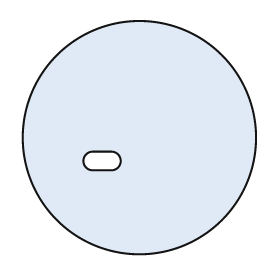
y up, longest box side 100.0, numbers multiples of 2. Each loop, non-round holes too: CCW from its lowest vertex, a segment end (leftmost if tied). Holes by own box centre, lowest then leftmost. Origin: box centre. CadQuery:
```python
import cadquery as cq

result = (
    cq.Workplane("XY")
    .moveTo(0.0, 0.0)
    .circle(50.0)
    .moveTo(-20.0, -14.0)
    .lineTo(-12.0, -14.0)
    .threePointArc((-8.0, -10.0), (-12.0, -6.0))
    .lineTo(-20.0, -6.0)
    .threePointArc((-24.0, -10.0), (-20.0, -14.0))
    .close()
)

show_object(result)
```